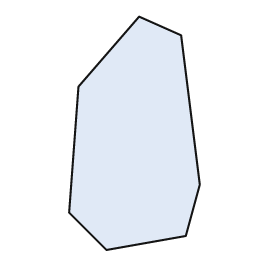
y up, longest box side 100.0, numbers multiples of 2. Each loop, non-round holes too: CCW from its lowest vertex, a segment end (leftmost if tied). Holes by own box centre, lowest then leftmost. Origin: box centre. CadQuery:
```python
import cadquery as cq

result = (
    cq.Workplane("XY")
    .moveTo(-12.0, -50.0)
    .lineTo(22.0, -44.0)
    .lineTo(28.0, -22.0)
    .lineTo(20.0, 42.0)
    .lineTo(2.0, 50.0)
    .lineTo(-24.0, 20.0)
    .lineTo(-28.0, -34.0)
    .close()
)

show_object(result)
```